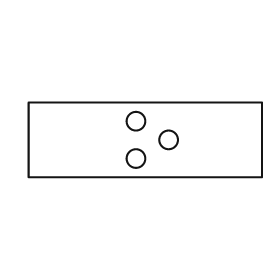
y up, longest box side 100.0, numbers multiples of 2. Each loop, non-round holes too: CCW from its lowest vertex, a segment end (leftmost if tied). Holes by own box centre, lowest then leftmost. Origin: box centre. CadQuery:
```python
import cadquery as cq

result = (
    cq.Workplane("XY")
    .moveTo(-50.0, -16.0)
    .lineTo(50.0, -16.0)
    .lineTo(50.0, 16.0)
    .lineTo(-50.0, 16.0)
    .close()
    .moveTo(-4.0, -8.0)
    .circle(4.0)
    .moveTo(10.0, 0.0)
    .circle(4.0)
    .moveTo(-4.0, 8.0)
    .circle(4.0)
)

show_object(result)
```